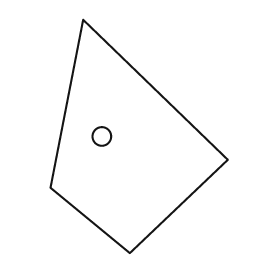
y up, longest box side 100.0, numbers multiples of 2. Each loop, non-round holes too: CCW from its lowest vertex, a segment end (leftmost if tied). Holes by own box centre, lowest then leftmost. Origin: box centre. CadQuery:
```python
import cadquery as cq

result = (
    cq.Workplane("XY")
    .moveTo(-4.0, -50.0)
    .lineTo(38.0, -10.0)
    .lineTo(-24.0, 50.0)
    .lineTo(-38.0, -22.0)
    .close()
    .moveTo(-16.0, 0.0)
    .circle(4.0)
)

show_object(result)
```